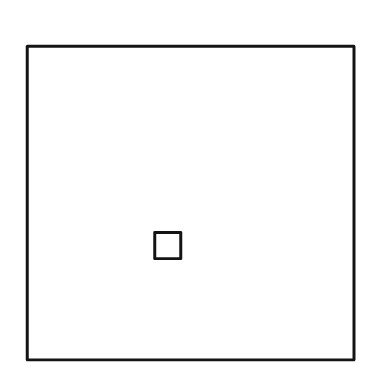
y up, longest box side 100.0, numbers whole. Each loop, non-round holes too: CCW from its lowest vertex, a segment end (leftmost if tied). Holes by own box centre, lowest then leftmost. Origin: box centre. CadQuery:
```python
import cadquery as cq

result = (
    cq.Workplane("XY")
    .moveTo(-50.0, -48.0)
    .lineTo(50.0, -48.0)
    .lineTo(50.0, 48.0)
    .lineTo(-50.0, 48.0)
    .close()
    .moveTo(-11.0, -17.0)
    .lineTo(-3.0, -17.0)
    .lineTo(-3.0, -9.0)
    .lineTo(-11.0, -9.0)
    .close()
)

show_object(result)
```